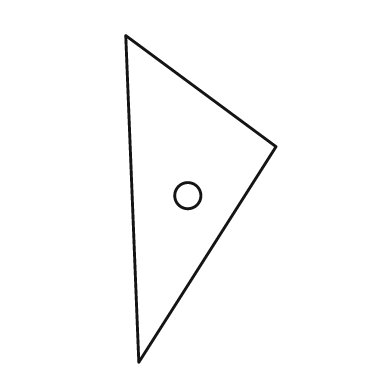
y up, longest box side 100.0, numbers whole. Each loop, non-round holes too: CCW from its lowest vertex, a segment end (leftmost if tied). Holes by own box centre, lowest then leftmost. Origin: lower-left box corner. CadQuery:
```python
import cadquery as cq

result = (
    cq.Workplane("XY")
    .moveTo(4.0, 0.0)
    .lineTo(46.0, 66.0)
    .lineTo(0.0, 100.0)
    .close()
    .moveTo(19.0, 51.0)
    .circle(4.0)
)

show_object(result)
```